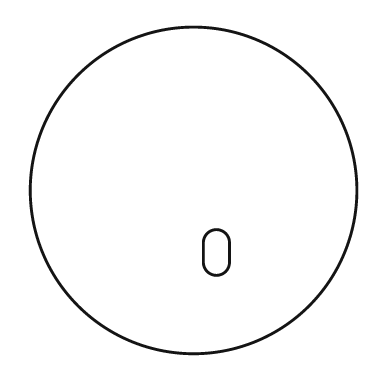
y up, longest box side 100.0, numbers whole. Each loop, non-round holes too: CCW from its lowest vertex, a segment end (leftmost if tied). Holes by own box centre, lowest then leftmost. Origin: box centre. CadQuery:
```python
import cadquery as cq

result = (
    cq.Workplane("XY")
    .moveTo(0.0, 0.0)
    .circle(50.0)
    .moveTo(3.0, -22.0)
    .threePointArc((7.0, -26.0), (11.0, -22.0))
    .lineTo(11.0, -16.0)
    .threePointArc((7.0, -12.0), (3.0, -16.0))
    .close()
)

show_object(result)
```